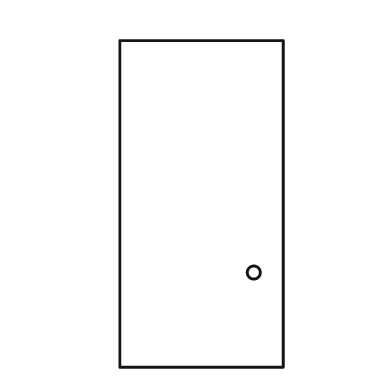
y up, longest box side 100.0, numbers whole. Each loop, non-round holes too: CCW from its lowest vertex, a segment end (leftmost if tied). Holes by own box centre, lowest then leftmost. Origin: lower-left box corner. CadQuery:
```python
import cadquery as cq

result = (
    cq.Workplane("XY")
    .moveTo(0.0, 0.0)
    .lineTo(50.0, 0.0)
    .lineTo(50.0, 100.0)
    .lineTo(0.0, 100.0)
    .close()
    .moveTo(41.0, 29.0)
    .circle(2.0)
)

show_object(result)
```